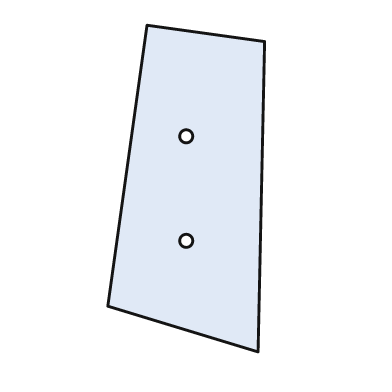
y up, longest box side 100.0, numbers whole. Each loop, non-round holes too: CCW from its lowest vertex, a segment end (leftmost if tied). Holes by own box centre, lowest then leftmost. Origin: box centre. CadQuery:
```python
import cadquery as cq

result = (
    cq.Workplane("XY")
    .moveTo(22.0, -50.0)
    .lineTo(24.0, 45.0)
    .lineTo(-12.0, 50.0)
    .lineTo(-24.0, -36.0)
    .close()
    .moveTo(0.0, -16.0)
    .circle(2.0)
    .moveTo(0.0, 16.0)
    .circle(2.0)
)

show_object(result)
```